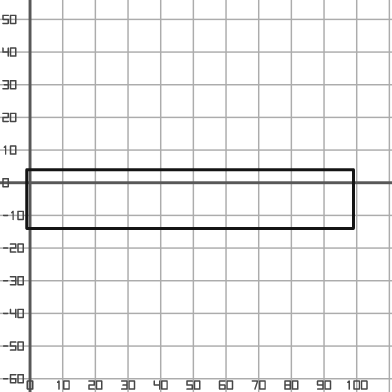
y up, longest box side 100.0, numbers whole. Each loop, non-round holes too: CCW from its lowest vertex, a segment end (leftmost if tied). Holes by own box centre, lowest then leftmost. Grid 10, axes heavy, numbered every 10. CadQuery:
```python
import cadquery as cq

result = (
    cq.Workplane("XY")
    .moveTo(-1.0, -14.0)
    .lineTo(99.0, -14.0)
    .lineTo(99.0, 4.0)
    .lineTo(-1.0, 4.0)
    .close()
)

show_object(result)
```